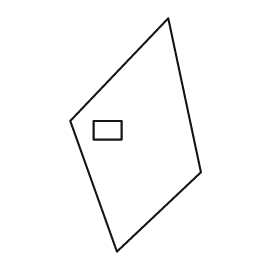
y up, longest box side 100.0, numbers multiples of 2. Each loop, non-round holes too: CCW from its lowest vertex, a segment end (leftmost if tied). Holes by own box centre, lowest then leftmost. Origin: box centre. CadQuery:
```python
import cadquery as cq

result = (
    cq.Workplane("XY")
    .moveTo(-8.0, -50.0)
    .lineTo(28.0, -16.0)
    .lineTo(14.0, 50.0)
    .lineTo(-28.0, 6.0)
    .close()
    .moveTo(-18.0, -2.0)
    .lineTo(-6.0, -2.0)
    .lineTo(-6.0, 6.0)
    .lineTo(-18.0, 6.0)
    .close()
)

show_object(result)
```